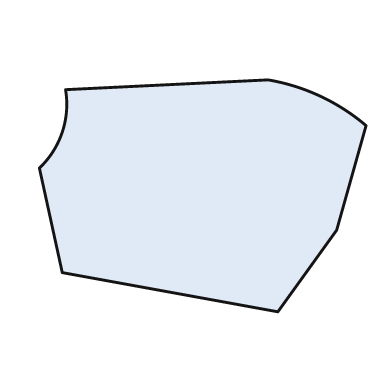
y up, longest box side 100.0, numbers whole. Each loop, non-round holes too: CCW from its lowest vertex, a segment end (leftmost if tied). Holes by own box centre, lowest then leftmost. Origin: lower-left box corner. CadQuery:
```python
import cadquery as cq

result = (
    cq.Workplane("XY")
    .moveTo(73.0, 0.0)
    .lineTo(91.0, 25.0)
    .lineTo(100.0, 57.0)
    .threePointArc((86.0, 66.0), (70.0, 71.0))
    .lineTo(8.0, 68.0)
    .threePointArc((7.0, 55.0), (0.0, 44.0))
    .lineTo(7.0, 12.0)
    .close()
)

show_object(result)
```